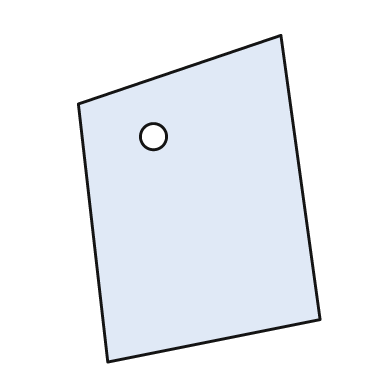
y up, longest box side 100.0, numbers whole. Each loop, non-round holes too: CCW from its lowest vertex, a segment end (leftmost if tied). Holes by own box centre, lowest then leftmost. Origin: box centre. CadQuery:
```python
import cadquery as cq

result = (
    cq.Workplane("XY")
    .moveTo(-28.0, -50.0)
    .lineTo(37.0, -37.0)
    .lineTo(25.0, 50.0)
    .lineTo(-37.0, 29.0)
    .close()
    .moveTo(-14.0, 19.0)
    .circle(4.0)
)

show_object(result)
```